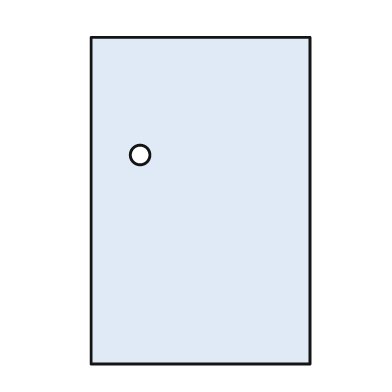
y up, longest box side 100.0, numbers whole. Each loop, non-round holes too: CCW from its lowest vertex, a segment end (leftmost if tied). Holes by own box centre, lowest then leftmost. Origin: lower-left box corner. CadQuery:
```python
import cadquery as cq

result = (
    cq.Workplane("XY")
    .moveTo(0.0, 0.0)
    .lineTo(67.0, 0.0)
    .lineTo(67.0, 100.0)
    .lineTo(0.0, 100.0)
    .close()
    .moveTo(15.0, 64.0)
    .circle(3.0)
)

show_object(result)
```